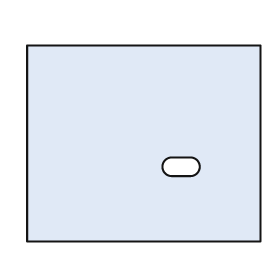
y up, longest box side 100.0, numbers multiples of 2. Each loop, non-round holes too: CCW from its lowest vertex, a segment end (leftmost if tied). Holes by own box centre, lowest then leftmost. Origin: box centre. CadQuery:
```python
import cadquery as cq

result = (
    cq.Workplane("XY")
    .moveTo(-50.0, -42.0)
    .lineTo(50.0, -42.0)
    .lineTo(50.0, 42.0)
    .lineTo(-50.0, 42.0)
    .close()
    .moveTo(12.0, -14.0)
    .lineTo(20.0, -14.0)
    .threePointArc((24.0, -10.0), (20.0, -6.0))
    .lineTo(12.0, -6.0)
    .threePointArc((8.0, -10.0), (12.0, -14.0))
    .close()
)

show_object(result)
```